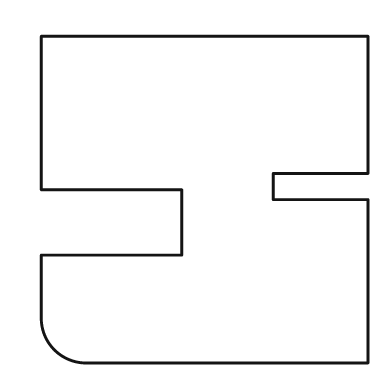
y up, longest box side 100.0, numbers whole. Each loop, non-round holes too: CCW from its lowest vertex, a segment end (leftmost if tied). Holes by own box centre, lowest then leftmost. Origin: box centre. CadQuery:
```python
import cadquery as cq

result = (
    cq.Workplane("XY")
    .moveTo(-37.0, -50.0)
    .lineTo(50.0, -50.0)
    .lineTo(50.0, 0.0)
    .lineTo(21.0, 0.0)
    .lineTo(21.0, 8.0)
    .lineTo(50.0, 8.0)
    .lineTo(50.0, 50.0)
    .lineTo(-50.0, 50.0)
    .lineTo(-50.0, 3.0)
    .lineTo(-7.0, 3.0)
    .lineTo(-7.0, -17.0)
    .lineTo(-50.0, -17.0)
    .lineTo(-50.0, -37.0)
    .threePointArc((-46.0, -46.0), (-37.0, -50.0))
    .close()
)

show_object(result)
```